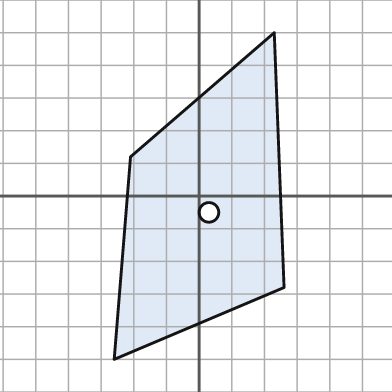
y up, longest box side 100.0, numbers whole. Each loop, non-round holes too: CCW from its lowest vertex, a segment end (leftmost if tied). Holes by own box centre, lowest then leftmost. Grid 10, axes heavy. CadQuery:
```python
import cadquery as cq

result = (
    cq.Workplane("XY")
    .moveTo(-26.0, -50.0)
    .lineTo(26.0, -28.0)
    .lineTo(23.0, 50.0)
    .lineTo(-21.0, 12.0)
    .close()
    .moveTo(3.0, -5.0)
    .circle(3.0)
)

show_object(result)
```